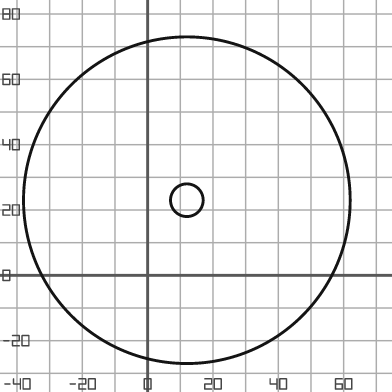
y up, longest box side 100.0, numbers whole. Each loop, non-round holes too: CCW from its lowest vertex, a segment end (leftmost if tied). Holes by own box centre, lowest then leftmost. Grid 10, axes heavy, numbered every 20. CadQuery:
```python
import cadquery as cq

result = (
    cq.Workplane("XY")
    .moveTo(12.0, 23.0)
    .circle(50.0)
    .moveTo(12.0, 23.0)
    .circle(5.0)
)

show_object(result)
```